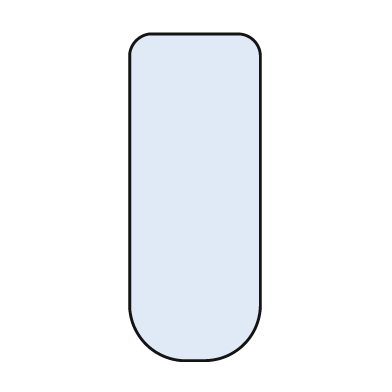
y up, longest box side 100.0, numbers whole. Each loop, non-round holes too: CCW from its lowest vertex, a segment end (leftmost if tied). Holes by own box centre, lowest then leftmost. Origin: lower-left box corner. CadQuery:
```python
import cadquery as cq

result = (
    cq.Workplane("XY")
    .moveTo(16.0, 0.0)
    .lineTo(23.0, 0.0)
    .threePointArc((35.0, 5.0), (40.0, 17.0))
    .lineTo(40.0, 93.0)
    .threePointArc((38.0, 98.0), (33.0, 100.0))
    .lineTo(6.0, 100.0)
    .threePointArc((2.0, 98.0), (0.0, 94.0))
    .lineTo(0.0, 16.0)
    .threePointArc((5.0, 5.0), (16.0, 0.0))
    .close()
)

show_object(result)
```